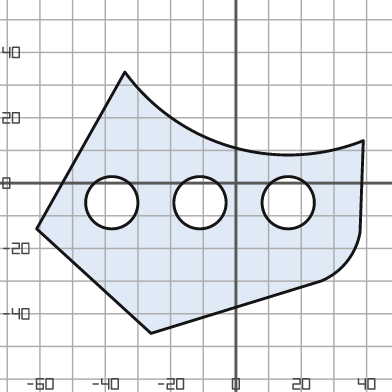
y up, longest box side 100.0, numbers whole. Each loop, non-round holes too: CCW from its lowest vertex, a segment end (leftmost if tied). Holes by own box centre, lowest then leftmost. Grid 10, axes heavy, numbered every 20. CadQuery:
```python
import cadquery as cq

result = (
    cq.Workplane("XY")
    .moveTo(-26.0, -46.0)
    .lineTo(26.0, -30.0)
    .threePointArc((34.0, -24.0), (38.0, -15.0))
    .lineTo(39.0, 13.0)
    .threePointArc((-1.0, 11.0), (-34.0, 34.0))
    .lineTo(-61.0, -14.0)
    .close()
    .moveTo(-38.0, -6.0)
    .circle(8.0)
    .moveTo(-11.0, -6.0)
    .circle(8.0)
    .moveTo(16.0, -6.0)
    .circle(8.0)
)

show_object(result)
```